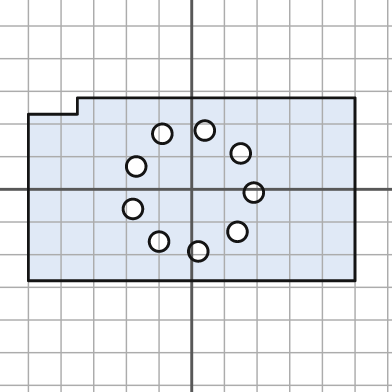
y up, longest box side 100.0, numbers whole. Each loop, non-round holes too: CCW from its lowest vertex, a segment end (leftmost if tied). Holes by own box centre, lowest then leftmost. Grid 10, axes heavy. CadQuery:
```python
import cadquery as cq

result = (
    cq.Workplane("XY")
    .moveTo(-50.0, -28.0)
    .lineTo(50.0, -28.0)
    .lineTo(50.0, 28.0)
    .lineTo(-35.0, 28.0)
    .lineTo(-35.0, 23.0)
    .lineTo(-50.0, 23.0)
    .close()
    .moveTo(2.0, -19.0)
    .circle(3.0)
    .moveTo(-10.0, -16.0)
    .circle(3.0)
    .moveTo(14.0, -13.0)
    .circle(3.0)
    .moveTo(-18.0, -6.0)
    .circle(3.0)
    .moveTo(19.0, -1.0)
    .circle(3.0)
    .moveTo(-17.0, 7.0)
    .circle(3.0)
    .moveTo(15.0, 11.0)
    .circle(3.0)
    .moveTo(-9.0, 17.0)
    .circle(3.0)
    .moveTo(4.0, 18.0)
    .circle(3.0)
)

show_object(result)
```